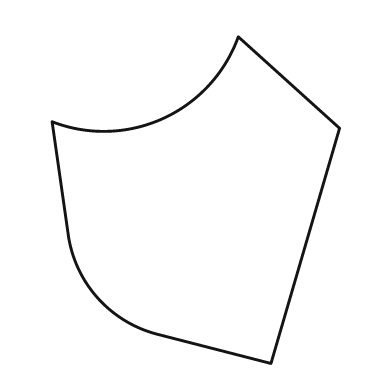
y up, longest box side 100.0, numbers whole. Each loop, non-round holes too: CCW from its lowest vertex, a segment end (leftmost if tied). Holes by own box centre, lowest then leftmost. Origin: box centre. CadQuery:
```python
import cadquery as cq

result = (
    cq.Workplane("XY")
    .moveTo(23.0, -50.0)
    .lineTo(44.0, 22.0)
    .lineTo(13.0, 50.0)
    .threePointArc((-10.0, 25.0), (-44.0, 24.0))
    .lineTo(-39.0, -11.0)
    .threePointArc((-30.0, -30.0), (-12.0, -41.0))
    .close()
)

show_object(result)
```